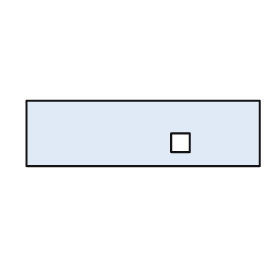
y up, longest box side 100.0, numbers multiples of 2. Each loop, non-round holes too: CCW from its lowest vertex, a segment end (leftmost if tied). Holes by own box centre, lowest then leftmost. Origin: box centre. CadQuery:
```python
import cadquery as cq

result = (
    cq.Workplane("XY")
    .moveTo(-50.0, -14.0)
    .lineTo(50.0, -14.0)
    .lineTo(50.0, 14.0)
    .lineTo(-50.0, 14.0)
    .close()
    .moveTo(12.0, -8.0)
    .lineTo(20.0, -8.0)
    .lineTo(20.0, 0.0)
    .lineTo(12.0, 0.0)
    .close()
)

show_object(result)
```